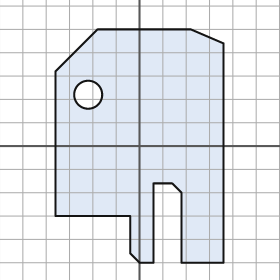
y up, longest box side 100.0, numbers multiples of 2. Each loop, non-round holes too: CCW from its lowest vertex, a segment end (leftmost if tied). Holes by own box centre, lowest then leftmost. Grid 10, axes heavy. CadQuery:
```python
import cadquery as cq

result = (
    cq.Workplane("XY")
    .moveTo(0.0, -50.0)
    .lineTo(6.0, -50.0)
    .lineTo(6.0, -16.0)
    .lineTo(14.0, -16.0)
    .lineTo(18.0, -20.0)
    .lineTo(18.0, -50.0)
    .lineTo(36.0, -50.0)
    .lineTo(36.0, 44.0)
    .lineTo(22.0, 50.0)
    .lineTo(-18.0, 50.0)
    .lineTo(-36.0, 32.0)
    .lineTo(-36.0, -30.0)
    .lineTo(-4.0, -30.0)
    .lineTo(-4.0, -46.0)
    .close()
    .moveTo(-22.0, 22.0)
    .circle(6.0)
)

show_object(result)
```